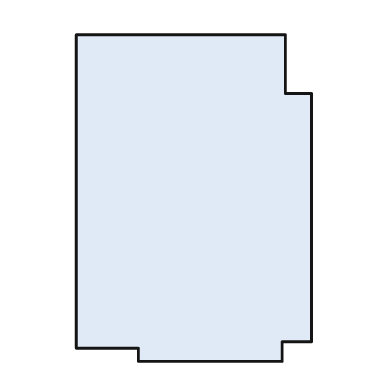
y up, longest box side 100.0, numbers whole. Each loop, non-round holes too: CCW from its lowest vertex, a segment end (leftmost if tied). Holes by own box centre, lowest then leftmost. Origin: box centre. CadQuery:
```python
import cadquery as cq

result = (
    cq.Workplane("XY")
    .moveTo(-17.0, -50.0)
    .lineTo(27.0, -50.0)
    .lineTo(27.0, -44.0)
    .lineTo(36.0, -44.0)
    .lineTo(36.0, 32.0)
    .lineTo(28.0, 32.0)
    .lineTo(28.0, 50.0)
    .lineTo(-36.0, 50.0)
    .lineTo(-36.0, -46.0)
    .lineTo(-17.0, -46.0)
    .close()
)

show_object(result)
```